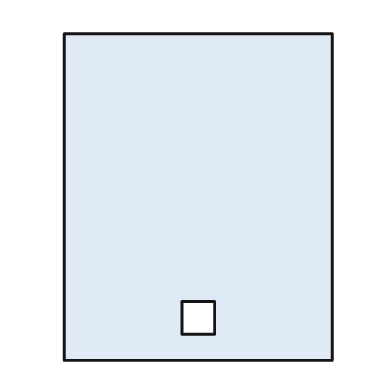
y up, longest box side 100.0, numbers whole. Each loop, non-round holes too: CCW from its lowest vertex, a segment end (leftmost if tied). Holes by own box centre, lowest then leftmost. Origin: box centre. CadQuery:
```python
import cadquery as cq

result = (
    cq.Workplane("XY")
    .moveTo(-41.0, -50.0)
    .lineTo(41.0, -50.0)
    .lineTo(41.0, 50.0)
    .lineTo(-41.0, 50.0)
    .close()
    .moveTo(-5.0, -42.0)
    .lineTo(5.0, -42.0)
    .lineTo(5.0, -32.0)
    .lineTo(-5.0, -32.0)
    .close()
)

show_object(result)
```